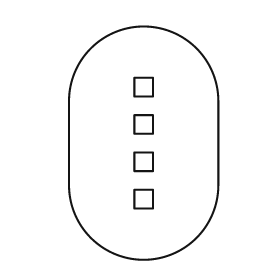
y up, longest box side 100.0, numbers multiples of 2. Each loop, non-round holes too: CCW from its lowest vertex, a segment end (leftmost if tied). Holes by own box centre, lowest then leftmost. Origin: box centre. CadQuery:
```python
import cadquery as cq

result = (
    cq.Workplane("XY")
    .moveTo(-32.0, -18.0)
    .threePointArc((0.0, -50.0), (32.0, -18.0))
    .lineTo(32.0, 18.0)
    .threePointArc((0.0, 50.0), (-32.0, 18.0))
    .close()
    .moveTo(-4.0, -28.0)
    .lineTo(4.0, -28.0)
    .lineTo(4.0, -20.0)
    .lineTo(-4.0, -20.0)
    .close()
    .moveTo(-4.0, -12.0)
    .lineTo(4.0, -12.0)
    .lineTo(4.0, -4.0)
    .lineTo(-4.0, -4.0)
    .close()
    .moveTo(-4.0, 4.0)
    .lineTo(4.0, 4.0)
    .lineTo(4.0, 12.0)
    .lineTo(-4.0, 12.0)
    .close()
    .moveTo(-4.0, 20.0)
    .lineTo(4.0, 20.0)
    .lineTo(4.0, 28.0)
    .lineTo(-4.0, 28.0)
    .close()
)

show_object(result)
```